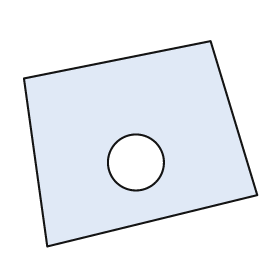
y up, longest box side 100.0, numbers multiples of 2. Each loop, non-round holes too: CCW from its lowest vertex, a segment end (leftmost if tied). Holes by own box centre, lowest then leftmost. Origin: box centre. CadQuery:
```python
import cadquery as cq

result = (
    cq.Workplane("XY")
    .moveTo(-40.0, -44.0)
    .lineTo(50.0, -22.0)
    .lineTo(30.0, 44.0)
    .lineTo(-50.0, 28.0)
    .close()
    .moveTo(-2.0, -8.0)
    .circle(12.0)
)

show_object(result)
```